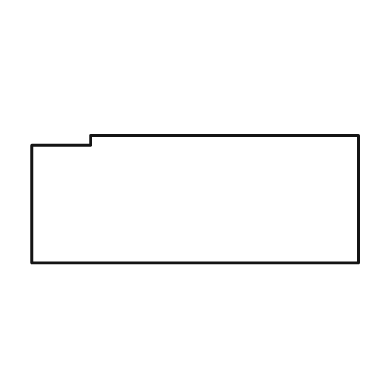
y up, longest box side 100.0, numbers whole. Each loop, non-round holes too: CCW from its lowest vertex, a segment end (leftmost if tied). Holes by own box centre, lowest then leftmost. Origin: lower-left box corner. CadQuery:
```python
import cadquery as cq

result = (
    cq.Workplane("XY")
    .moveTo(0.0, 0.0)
    .lineTo(100.0, 0.0)
    .lineTo(100.0, 39.0)
    .lineTo(18.0, 39.0)
    .lineTo(18.0, 36.0)
    .lineTo(0.0, 36.0)
    .close()
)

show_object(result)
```